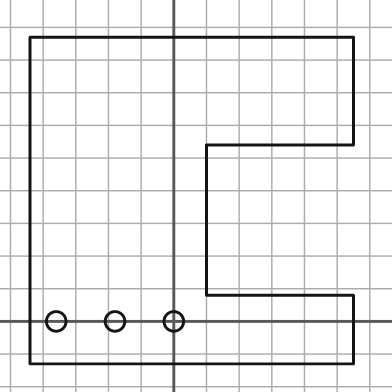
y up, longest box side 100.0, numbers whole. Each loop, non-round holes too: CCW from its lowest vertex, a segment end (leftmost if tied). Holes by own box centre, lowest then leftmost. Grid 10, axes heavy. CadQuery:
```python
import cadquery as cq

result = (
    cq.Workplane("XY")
    .moveTo(-44.0, -13.0)
    .lineTo(55.0, -13.0)
    .lineTo(55.0, 8.0)
    .lineTo(10.0, 8.0)
    .lineTo(10.0, 54.0)
    .lineTo(55.0, 54.0)
    .lineTo(55.0, 87.0)
    .lineTo(-44.0, 87.0)
    .close()
    .moveTo(-36.0, 0.0)
    .circle(3.0)
    .moveTo(-18.0, 0.0)
    .circle(3.0)
    .moveTo(0.0, 0.0)
    .circle(3.0)
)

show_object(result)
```